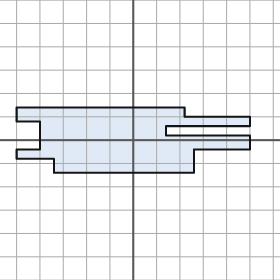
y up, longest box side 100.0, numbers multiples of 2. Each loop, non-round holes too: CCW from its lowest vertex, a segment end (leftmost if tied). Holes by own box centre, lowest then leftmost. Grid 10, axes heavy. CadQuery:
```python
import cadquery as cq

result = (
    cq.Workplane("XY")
    .moveTo(-34.0, -14.0)
    .lineTo(26.0, -14.0)
    .lineTo(26.0, -4.0)
    .lineTo(50.0, -4.0)
    .lineTo(50.0, 2.0)
    .lineTo(14.0, 2.0)
    .lineTo(14.0, 6.0)
    .lineTo(50.0, 6.0)
    .lineTo(50.0, 10.0)
    .lineTo(22.0, 10.0)
    .lineTo(22.0, 14.0)
    .lineTo(-50.0, 14.0)
    .lineTo(-50.0, 8.0)
    .lineTo(-40.0, 8.0)
    .lineTo(-40.0, -4.0)
    .lineTo(-50.0, -4.0)
    .lineTo(-50.0, -8.0)
    .lineTo(-34.0, -8.0)
    .close()
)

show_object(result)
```